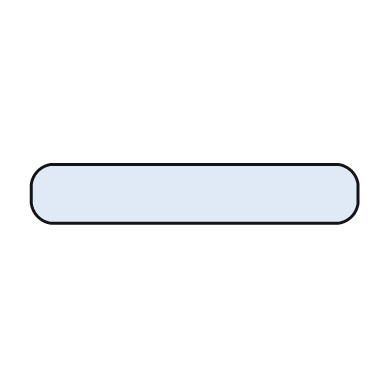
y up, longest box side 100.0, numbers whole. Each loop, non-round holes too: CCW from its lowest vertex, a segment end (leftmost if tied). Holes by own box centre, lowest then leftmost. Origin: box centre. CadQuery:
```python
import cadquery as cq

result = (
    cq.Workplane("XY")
    .moveTo(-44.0, -9.0)
    .lineTo(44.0, -9.0)
    .threePointArc((48.0, -7.0), (50.0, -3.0))
    .lineTo(50.0, 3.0)
    .threePointArc((48.0, 7.0), (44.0, 9.0))
    .lineTo(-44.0, 9.0)
    .threePointArc((-48.0, 7.0), (-50.0, 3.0))
    .lineTo(-50.0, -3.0)
    .threePointArc((-48.0, -7.0), (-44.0, -9.0))
    .close()
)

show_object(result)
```